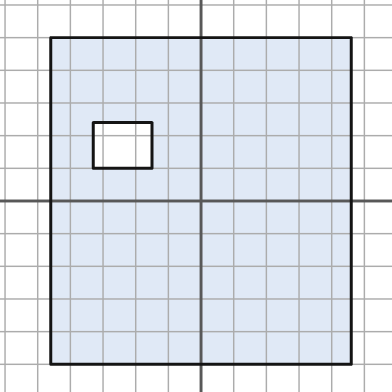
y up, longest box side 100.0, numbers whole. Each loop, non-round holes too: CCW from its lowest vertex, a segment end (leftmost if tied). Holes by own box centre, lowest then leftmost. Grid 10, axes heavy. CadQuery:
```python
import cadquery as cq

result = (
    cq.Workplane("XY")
    .moveTo(-46.0, -50.0)
    .lineTo(46.0, -50.0)
    .lineTo(46.0, 50.0)
    .lineTo(-46.0, 50.0)
    .close()
    .moveTo(-33.0, 10.0)
    .lineTo(-15.0, 10.0)
    .lineTo(-15.0, 24.0)
    .lineTo(-33.0, 24.0)
    .close()
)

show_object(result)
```